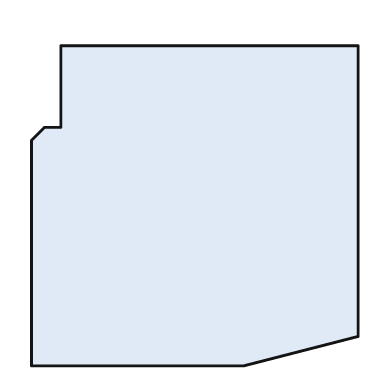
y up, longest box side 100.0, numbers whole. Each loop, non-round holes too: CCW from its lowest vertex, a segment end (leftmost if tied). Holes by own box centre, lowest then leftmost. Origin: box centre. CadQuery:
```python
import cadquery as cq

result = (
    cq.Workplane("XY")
    .moveTo(-50.0, -49.0)
    .lineTo(15.0, -49.0)
    .lineTo(50.0, -40.0)
    .lineTo(50.0, 49.0)
    .lineTo(-41.0, 49.0)
    .lineTo(-41.0, 24.0)
    .lineTo(-46.0, 24.0)
    .lineTo(-50.0, 20.0)
    .close()
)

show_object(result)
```